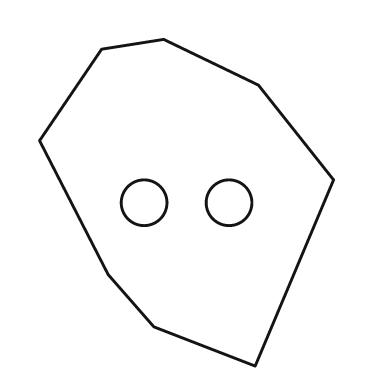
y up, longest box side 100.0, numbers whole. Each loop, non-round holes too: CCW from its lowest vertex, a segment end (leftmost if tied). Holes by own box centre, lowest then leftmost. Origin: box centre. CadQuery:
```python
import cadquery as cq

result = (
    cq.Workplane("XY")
    .moveTo(21.0, -50.0)
    .lineTo(45.0, 7.0)
    .lineTo(22.0, 36.0)
    .lineTo(-7.0, 50.0)
    .lineTo(-26.0, 47.0)
    .lineTo(-45.0, 19.0)
    .lineTo(-24.0, -22.0)
    .lineTo(-10.0, -38.0)
    .close()
    .moveTo(-13.0, 0.0)
    .circle(7.0)
    .moveTo(13.0, 0.0)
    .circle(7.0)
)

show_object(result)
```